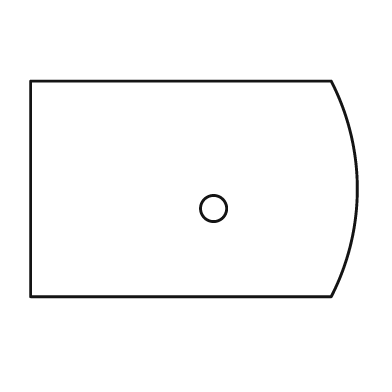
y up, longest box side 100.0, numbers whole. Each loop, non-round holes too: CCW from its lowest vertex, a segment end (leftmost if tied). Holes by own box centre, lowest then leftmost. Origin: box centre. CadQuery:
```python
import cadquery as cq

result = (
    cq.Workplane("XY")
    .moveTo(-50.0, -33.0)
    .lineTo(42.0, -33.0)
    .threePointArc((50.0, 0.0), (42.0, 33.0))
    .lineTo(-50.0, 33.0)
    .close()
    .moveTo(6.0, -6.0)
    .circle(4.0)
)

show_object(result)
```